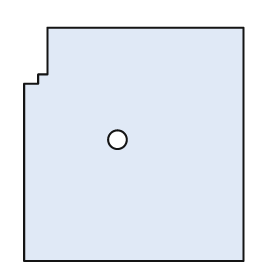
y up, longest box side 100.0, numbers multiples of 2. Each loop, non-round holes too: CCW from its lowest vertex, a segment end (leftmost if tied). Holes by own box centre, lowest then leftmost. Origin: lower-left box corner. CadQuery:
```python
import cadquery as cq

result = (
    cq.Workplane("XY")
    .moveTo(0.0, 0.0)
    .lineTo(94.0, 0.0)
    .lineTo(94.0, 100.0)
    .lineTo(10.0, 100.0)
    .lineTo(10.0, 80.0)
    .lineTo(6.0, 80.0)
    .lineTo(6.0, 76.0)
    .lineTo(0.0, 76.0)
    .close()
    .moveTo(40.0, 52.0)
    .circle(4.0)
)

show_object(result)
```